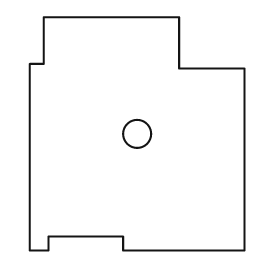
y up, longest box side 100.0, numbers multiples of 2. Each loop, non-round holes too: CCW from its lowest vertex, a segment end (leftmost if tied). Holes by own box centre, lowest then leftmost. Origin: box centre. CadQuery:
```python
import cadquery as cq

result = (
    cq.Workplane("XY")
    .moveTo(-46.0, -50.0)
    .lineTo(-38.0, -50.0)
    .lineTo(-38.0, -44.0)
    .lineTo(-6.0, -44.0)
    .lineTo(-6.0, -50.0)
    .lineTo(46.0, -50.0)
    .lineTo(46.0, 28.0)
    .lineTo(18.0, 28.0)
    .lineTo(18.0, 50.0)
    .lineTo(-40.0, 50.0)
    .lineTo(-40.0, 30.0)
    .lineTo(-46.0, 30.0)
    .close()
    .moveTo(0.0, 0.0)
    .circle(6.0)
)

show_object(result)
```